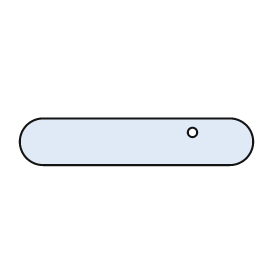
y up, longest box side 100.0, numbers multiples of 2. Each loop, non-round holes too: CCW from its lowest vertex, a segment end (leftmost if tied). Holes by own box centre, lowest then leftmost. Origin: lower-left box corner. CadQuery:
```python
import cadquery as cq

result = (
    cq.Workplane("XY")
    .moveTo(10.0, 0.0)
    .lineTo(90.0, 0.0)
    .threePointArc((100.0, 10.0), (90.0, 20.0))
    .lineTo(10.0, 20.0)
    .threePointArc((0.0, 10.0), (10.0, 0.0))
    .close()
    .moveTo(74.0, 14.0)
    .circle(2.0)
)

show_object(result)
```